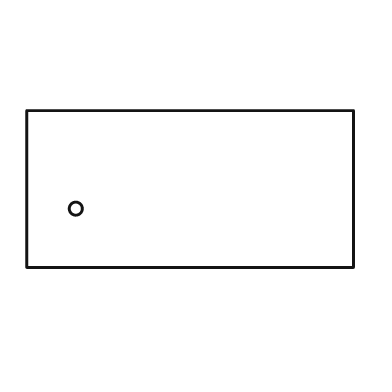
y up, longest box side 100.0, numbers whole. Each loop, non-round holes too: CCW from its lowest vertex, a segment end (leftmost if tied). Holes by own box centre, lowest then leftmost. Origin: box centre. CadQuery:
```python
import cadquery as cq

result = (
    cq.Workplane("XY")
    .moveTo(-50.0, -24.0)
    .lineTo(50.0, -24.0)
    .lineTo(50.0, 24.0)
    .lineTo(-50.0, 24.0)
    .close()
    .moveTo(-35.0, -6.0)
    .circle(2.0)
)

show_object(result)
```